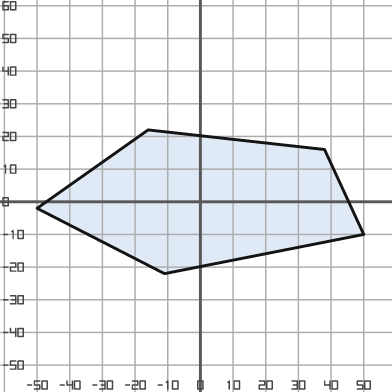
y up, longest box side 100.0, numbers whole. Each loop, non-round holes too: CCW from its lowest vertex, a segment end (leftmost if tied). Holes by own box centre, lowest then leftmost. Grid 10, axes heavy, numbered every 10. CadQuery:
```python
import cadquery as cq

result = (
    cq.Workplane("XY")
    .moveTo(-11.0, -22.0)
    .lineTo(50.0, -10.0)
    .lineTo(38.0, 16.0)
    .lineTo(-16.0, 22.0)
    .lineTo(-50.0, -2.0)
    .close()
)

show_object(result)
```